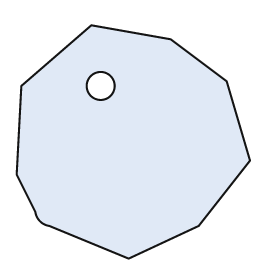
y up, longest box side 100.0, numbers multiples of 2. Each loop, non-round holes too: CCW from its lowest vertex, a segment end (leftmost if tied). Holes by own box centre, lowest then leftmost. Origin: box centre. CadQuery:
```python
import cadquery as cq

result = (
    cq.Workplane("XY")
    .moveTo(-2.0, -50.0)
    .lineTo(28.0, -36.0)
    .lineTo(50.0, -8.0)
    .lineTo(40.0, 26.0)
    .lineTo(16.0, 44.0)
    .lineTo(-18.0, 50.0)
    .lineTo(-48.0, 24.0)
    .lineTo(-50.0, -14.0)
    .lineTo(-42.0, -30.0)
    .threePointArc((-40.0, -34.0), (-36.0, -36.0))
    .close()
    .moveTo(-14.0, 24.0)
    .circle(6.0)
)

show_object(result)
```